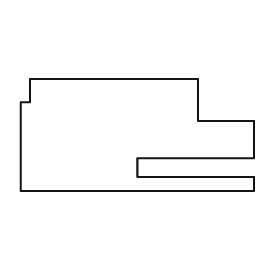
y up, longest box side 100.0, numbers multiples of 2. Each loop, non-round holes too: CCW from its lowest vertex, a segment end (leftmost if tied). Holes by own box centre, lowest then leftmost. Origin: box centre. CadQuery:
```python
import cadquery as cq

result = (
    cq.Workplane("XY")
    .moveTo(-50.0, -24.0)
    .lineTo(50.0, -24.0)
    .lineTo(50.0, -18.0)
    .lineTo(0.0, -18.0)
    .lineTo(0.0, -10.0)
    .lineTo(50.0, -10.0)
    .lineTo(50.0, 6.0)
    .lineTo(26.0, 6.0)
    .lineTo(26.0, 24.0)
    .lineTo(-46.0, 24.0)
    .lineTo(-46.0, 14.0)
    .lineTo(-50.0, 14.0)
    .close()
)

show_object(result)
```